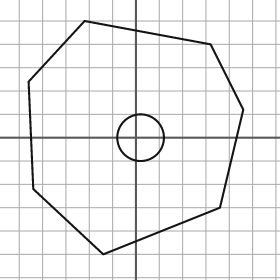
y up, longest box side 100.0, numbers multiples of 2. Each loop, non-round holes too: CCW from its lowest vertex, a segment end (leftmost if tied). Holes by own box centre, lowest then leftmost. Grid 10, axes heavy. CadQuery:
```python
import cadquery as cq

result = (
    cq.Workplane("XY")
    .moveTo(-14.0, -50.0)
    .lineTo(36.0, -30.0)
    .lineTo(46.0, 12.0)
    .lineTo(32.0, 40.0)
    .lineTo(-22.0, 50.0)
    .lineTo(-46.0, 24.0)
    .lineTo(-44.0, -22.0)
    .close()
    .moveTo(2.0, 0.0)
    .circle(10.0)
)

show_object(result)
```